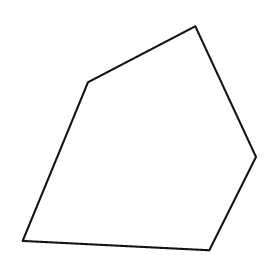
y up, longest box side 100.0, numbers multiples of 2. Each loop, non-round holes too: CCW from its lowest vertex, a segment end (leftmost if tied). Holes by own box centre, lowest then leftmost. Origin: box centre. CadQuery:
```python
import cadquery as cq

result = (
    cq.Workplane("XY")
    .moveTo(30.0, -48.0)
    .lineTo(50.0, -8.0)
    .lineTo(24.0, 48.0)
    .lineTo(-22.0, 24.0)
    .lineTo(-50.0, -44.0)
    .close()
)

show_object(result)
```